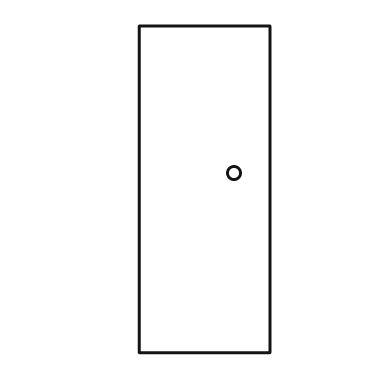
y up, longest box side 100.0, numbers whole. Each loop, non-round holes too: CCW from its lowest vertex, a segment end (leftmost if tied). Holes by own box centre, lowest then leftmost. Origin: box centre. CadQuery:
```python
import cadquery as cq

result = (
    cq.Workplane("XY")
    .moveTo(-20.0, -50.0)
    .lineTo(20.0, -50.0)
    .lineTo(20.0, 50.0)
    .lineTo(-20.0, 50.0)
    .close()
    .moveTo(9.0, 5.0)
    .circle(2.0)
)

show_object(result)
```